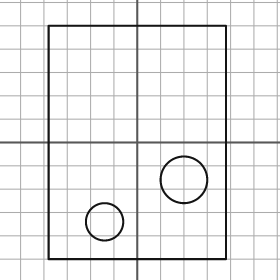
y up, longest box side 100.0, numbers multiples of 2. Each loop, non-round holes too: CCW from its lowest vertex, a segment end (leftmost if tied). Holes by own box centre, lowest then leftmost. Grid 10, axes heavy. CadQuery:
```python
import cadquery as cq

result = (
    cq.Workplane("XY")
    .moveTo(-38.0, -50.0)
    .lineTo(38.0, -50.0)
    .lineTo(38.0, 50.0)
    .lineTo(-38.0, 50.0)
    .close()
    .moveTo(-14.0, -34.0)
    .circle(8.0)
    .moveTo(20.0, -16.0)
    .circle(10.0)
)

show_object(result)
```